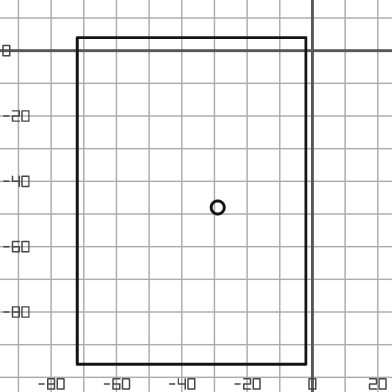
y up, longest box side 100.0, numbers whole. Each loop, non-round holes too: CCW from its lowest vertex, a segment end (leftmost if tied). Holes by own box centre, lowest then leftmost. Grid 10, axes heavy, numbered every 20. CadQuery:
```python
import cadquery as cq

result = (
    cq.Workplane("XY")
    .moveTo(-72.0, -96.0)
    .lineTo(-2.0, -96.0)
    .lineTo(-2.0, 4.0)
    .lineTo(-72.0, 4.0)
    .close()
    .moveTo(-29.0, -48.0)
    .circle(2.0)
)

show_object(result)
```